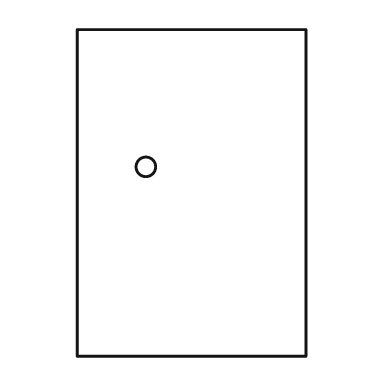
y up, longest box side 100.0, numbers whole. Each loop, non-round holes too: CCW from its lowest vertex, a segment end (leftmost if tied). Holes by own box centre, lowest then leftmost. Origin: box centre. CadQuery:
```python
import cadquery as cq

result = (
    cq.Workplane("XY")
    .moveTo(-35.0, -50.0)
    .lineTo(35.0, -50.0)
    .lineTo(35.0, 50.0)
    .lineTo(-35.0, 50.0)
    .close()
    .moveTo(-14.0, 8.0)
    .circle(3.0)
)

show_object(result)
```